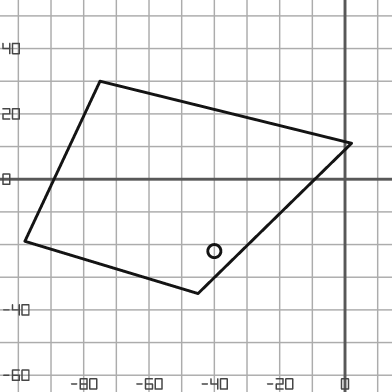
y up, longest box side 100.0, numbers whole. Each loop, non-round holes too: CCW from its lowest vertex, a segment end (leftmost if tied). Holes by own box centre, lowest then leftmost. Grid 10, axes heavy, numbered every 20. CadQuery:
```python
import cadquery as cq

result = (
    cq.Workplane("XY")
    .moveTo(-45.0, -35.0)
    .lineTo(2.0, 11.0)
    .lineTo(-75.0, 30.0)
    .lineTo(-98.0, -19.0)
    .close()
    .moveTo(-40.0, -22.0)
    .circle(2.0)
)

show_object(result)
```